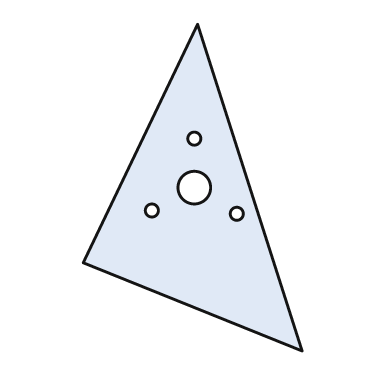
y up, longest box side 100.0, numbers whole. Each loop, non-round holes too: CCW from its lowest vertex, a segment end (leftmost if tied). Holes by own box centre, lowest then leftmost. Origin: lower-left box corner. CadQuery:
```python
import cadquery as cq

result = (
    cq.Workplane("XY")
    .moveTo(67.0, 0.0)
    .lineTo(35.0, 100.0)
    .lineTo(0.0, 27.0)
    .close()
    .moveTo(47.0, 42.0)
    .circle(2.0)
    .moveTo(21.0, 43.0)
    .circle(2.0)
    .moveTo(34.0, 50.0)
    .circle(5.0)
    .moveTo(34.0, 65.0)
    .circle(2.0)
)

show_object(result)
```